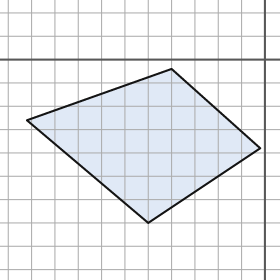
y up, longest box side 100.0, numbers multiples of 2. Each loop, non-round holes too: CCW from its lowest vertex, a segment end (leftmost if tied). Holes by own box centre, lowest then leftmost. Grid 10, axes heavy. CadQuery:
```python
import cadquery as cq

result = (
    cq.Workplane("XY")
    .moveTo(-50.0, -70.0)
    .lineTo(-2.0, -38.0)
    .lineTo(-40.0, -4.0)
    .lineTo(-102.0, -26.0)
    .close()
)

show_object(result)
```